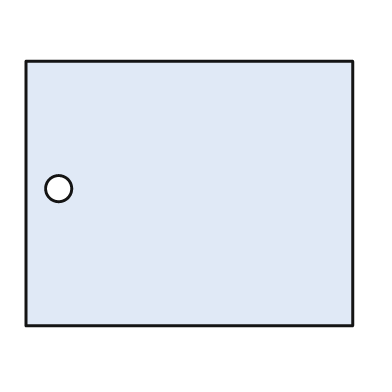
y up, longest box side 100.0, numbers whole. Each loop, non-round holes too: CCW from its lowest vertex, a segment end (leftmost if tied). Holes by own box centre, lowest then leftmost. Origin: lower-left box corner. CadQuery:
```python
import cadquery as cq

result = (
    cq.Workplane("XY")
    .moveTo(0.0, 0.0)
    .lineTo(100.0, 0.0)
    .lineTo(100.0, 81.0)
    .lineTo(0.0, 81.0)
    .close()
    .moveTo(10.0, 42.0)
    .circle(4.0)
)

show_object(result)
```